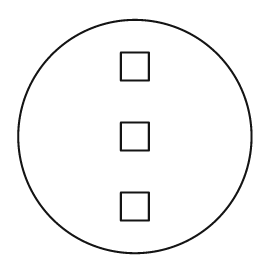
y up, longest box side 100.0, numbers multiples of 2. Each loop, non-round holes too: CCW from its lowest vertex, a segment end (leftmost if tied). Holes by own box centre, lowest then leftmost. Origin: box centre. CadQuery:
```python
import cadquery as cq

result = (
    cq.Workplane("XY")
    .moveTo(0.0, 0.0)
    .circle(50.0)
    .moveTo(-6.0, -36.0)
    .lineTo(6.0, -36.0)
    .lineTo(6.0, -24.0)
    .lineTo(-6.0, -24.0)
    .close()
    .moveTo(-6.0, -6.0)
    .lineTo(6.0, -6.0)
    .lineTo(6.0, 6.0)
    .lineTo(-6.0, 6.0)
    .close()
    .moveTo(-6.0, 24.0)
    .lineTo(6.0, 24.0)
    .lineTo(6.0, 36.0)
    .lineTo(-6.0, 36.0)
    .close()
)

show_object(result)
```